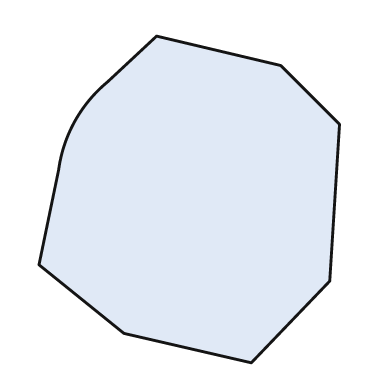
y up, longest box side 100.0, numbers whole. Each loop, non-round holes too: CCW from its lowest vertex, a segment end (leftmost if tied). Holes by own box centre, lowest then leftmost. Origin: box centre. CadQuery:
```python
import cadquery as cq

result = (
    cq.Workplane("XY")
    .moveTo(19.0, -50.0)
    .lineTo(43.0, -25.0)
    .lineTo(46.0, 23.0)
    .lineTo(28.0, 41.0)
    .lineTo(-10.0, 50.0)
    .lineTo(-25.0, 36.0)
    .threePointArc((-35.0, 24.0), (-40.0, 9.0))
    .lineTo(-46.0, -20.0)
    .lineTo(-20.0, -41.0)
    .close()
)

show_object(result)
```